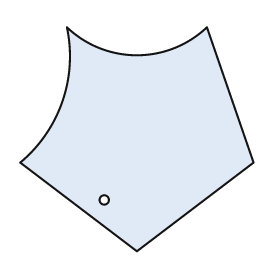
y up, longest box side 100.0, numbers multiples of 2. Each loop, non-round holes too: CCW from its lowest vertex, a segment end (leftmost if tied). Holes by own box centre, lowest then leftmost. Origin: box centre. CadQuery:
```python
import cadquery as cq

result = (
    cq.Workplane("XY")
    .moveTo(0.0, -48.0)
    .lineTo(50.0, -10.0)
    .lineTo(30.0, 48.0)
    .threePointArc((0.0, 36.0), (-30.0, 48.0))
    .threePointArc((-32.0, 16.0), (-50.0, -10.0))
    .close()
    .moveTo(-14.0, -26.0)
    .circle(2.0)
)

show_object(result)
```